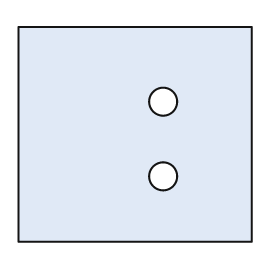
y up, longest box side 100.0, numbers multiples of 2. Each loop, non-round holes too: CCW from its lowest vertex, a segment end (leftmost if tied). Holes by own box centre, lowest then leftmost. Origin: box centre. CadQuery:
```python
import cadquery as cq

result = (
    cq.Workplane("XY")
    .moveTo(-50.0, -46.0)
    .lineTo(50.0, -46.0)
    .lineTo(50.0, 46.0)
    .lineTo(-50.0, 46.0)
    .close()
    .moveTo(12.0, -18.0)
    .circle(6.0)
    .moveTo(12.0, 14.0)
    .circle(6.0)
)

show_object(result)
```